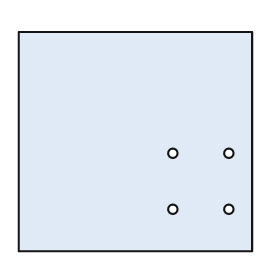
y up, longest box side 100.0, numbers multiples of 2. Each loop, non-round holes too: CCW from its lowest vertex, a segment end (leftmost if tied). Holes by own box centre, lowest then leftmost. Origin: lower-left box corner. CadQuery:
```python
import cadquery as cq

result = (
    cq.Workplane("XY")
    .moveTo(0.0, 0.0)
    .lineTo(100.0, 0.0)
    .lineTo(100.0, 94.0)
    .lineTo(0.0, 94.0)
    .close()
    .moveTo(66.0, 18.0)
    .circle(2.0)
    .moveTo(90.0, 18.0)
    .circle(2.0)
    .moveTo(66.0, 42.0)
    .circle(2.0)
    .moveTo(90.0, 42.0)
    .circle(2.0)
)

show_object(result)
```